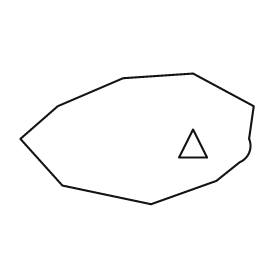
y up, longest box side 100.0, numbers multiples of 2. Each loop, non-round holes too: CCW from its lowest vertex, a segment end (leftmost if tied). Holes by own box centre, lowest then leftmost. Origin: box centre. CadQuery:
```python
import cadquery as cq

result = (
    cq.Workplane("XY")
    .moveTo(6.0, -28.0)
    .lineTo(34.0, -18.0)
    .lineTo(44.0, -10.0)
    .threePointArc((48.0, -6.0), (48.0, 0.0))
    .lineTo(50.0, 14.0)
    .lineTo(24.0, 28.0)
    .lineTo(-6.0, 26.0)
    .lineTo(-34.0, 14.0)
    .lineTo(-50.0, 0.0)
    .lineTo(-32.0, -20.0)
    .close()
    .moveTo(18.0, -8.0)
    .lineTo(30.0, -8.0)
    .lineTo(24.0, 4.0)
    .close()
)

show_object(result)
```